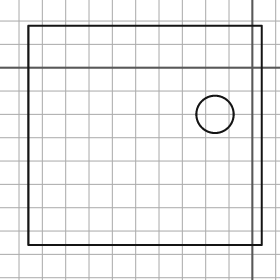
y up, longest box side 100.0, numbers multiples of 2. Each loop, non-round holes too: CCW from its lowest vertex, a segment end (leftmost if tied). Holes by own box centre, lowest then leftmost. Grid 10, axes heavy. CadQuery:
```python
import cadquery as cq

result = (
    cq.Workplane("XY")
    .moveTo(-96.0, -76.0)
    .lineTo(4.0, -76.0)
    .lineTo(4.0, 18.0)
    .lineTo(-96.0, 18.0)
    .close()
    .moveTo(-16.0, -20.0)
    .circle(8.0)
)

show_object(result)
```